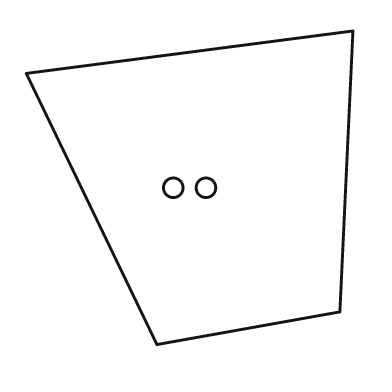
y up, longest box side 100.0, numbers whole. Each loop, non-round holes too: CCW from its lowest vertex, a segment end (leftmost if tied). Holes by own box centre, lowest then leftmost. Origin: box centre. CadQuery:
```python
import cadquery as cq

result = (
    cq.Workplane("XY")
    .moveTo(-10.0, -48.0)
    .lineTo(46.0, -38.0)
    .lineTo(50.0, 48.0)
    .lineTo(-50.0, 35.0)
    .close()
    .moveTo(-5.0, 0.0)
    .circle(3.0)
    .moveTo(5.0, 0.0)
    .circle(3.0)
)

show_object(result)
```